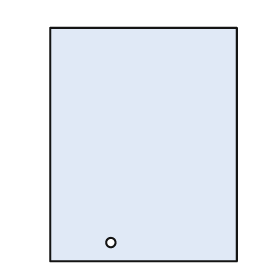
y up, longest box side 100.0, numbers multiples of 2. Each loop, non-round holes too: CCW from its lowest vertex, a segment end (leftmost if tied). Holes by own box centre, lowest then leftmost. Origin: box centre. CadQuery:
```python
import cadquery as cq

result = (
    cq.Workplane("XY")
    .moveTo(-40.0, -50.0)
    .lineTo(40.0, -50.0)
    .lineTo(40.0, 50.0)
    .lineTo(-40.0, 50.0)
    .close()
    .moveTo(-14.0, -42.0)
    .circle(2.0)
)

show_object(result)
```